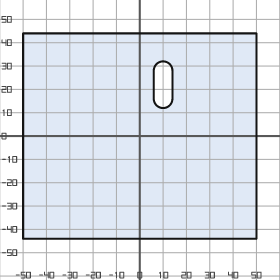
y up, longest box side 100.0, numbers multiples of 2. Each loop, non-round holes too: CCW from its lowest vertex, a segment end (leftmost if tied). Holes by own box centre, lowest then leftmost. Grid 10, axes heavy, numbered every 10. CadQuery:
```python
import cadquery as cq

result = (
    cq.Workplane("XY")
    .moveTo(-50.0, -44.0)
    .lineTo(50.0, -44.0)
    .lineTo(50.0, 44.0)
    .lineTo(-50.0, 44.0)
    .close()
    .moveTo(6.0, 16.0)
    .threePointArc((10.0, 12.0), (14.0, 16.0))
    .lineTo(14.0, 28.0)
    .threePointArc((10.0, 32.0), (6.0, 28.0))
    .close()
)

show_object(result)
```